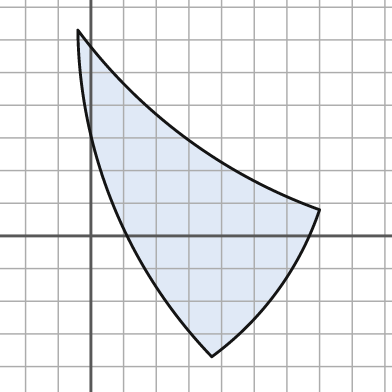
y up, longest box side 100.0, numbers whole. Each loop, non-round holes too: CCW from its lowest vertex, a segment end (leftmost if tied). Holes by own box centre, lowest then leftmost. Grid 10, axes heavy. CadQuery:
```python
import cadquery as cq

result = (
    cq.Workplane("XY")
    .moveTo(37.0, -37.0)
    .threePointArc((57.0, -17.0), (70.0, 8.0))
    .threePointArc((29.0, 30.0), (-4.0, 63.0))
    .threePointArc((7.0, 9.0), (37.0, -37.0))
    .close()
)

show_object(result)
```